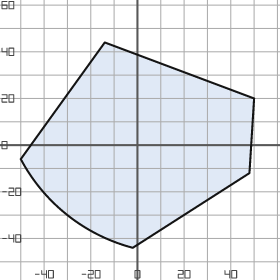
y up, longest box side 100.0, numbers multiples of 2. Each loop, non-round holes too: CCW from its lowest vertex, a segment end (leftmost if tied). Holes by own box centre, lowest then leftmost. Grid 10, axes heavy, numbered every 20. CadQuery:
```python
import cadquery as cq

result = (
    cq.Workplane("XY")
    .moveTo(-2.0, -44.0)
    .lineTo(48.0, -12.0)
    .lineTo(50.0, 20.0)
    .lineTo(-14.0, 44.0)
    .lineTo(-50.0, -6.0)
    .threePointArc((-30.0, -30.0), (-2.0, -44.0))
    .close()
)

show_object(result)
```